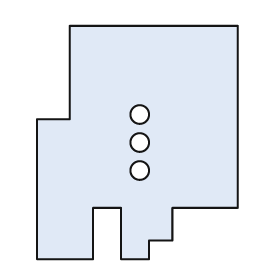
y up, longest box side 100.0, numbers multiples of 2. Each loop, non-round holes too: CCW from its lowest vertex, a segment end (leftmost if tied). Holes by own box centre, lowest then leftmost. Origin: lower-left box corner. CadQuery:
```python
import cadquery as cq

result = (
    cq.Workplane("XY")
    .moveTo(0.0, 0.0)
    .lineTo(24.0, 0.0)
    .lineTo(24.0, 22.0)
    .lineTo(36.0, 22.0)
    .lineTo(36.0, 0.0)
    .lineTo(48.0, 0.0)
    .lineTo(48.0, 8.0)
    .lineTo(58.0, 8.0)
    .lineTo(58.0, 22.0)
    .lineTo(86.0, 22.0)
    .lineTo(86.0, 100.0)
    .lineTo(14.0, 100.0)
    .lineTo(14.0, 60.0)
    .lineTo(0.0, 60.0)
    .close()
    .moveTo(44.0, 38.0)
    .circle(4.0)
    .moveTo(44.0, 50.0)
    .circle(4.0)
    .moveTo(44.0, 62.0)
    .circle(4.0)
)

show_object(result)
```